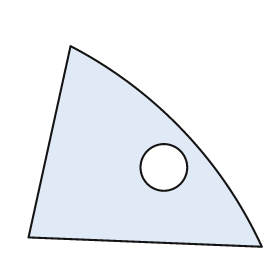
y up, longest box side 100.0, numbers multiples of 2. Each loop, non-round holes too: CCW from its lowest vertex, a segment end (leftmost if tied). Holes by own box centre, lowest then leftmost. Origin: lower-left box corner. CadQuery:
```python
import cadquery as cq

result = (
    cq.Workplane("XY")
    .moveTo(100.0, 0.0)
    .threePointArc((66.0, 50.0), (18.0, 86.0))
    .lineTo(0.0, 4.0)
    .close()
    .moveTo(58.0, 34.0)
    .circle(10.0)
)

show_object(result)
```